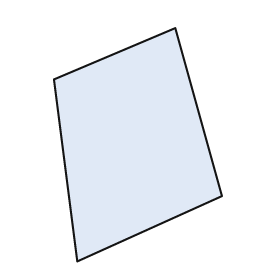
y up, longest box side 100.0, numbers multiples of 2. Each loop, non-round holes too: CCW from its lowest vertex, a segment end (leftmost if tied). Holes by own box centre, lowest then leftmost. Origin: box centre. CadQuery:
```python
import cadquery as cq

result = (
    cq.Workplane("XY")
    .moveTo(-26.0, -50.0)
    .lineTo(36.0, -22.0)
    .lineTo(16.0, 50.0)
    .lineTo(-36.0, 28.0)
    .close()
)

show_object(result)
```